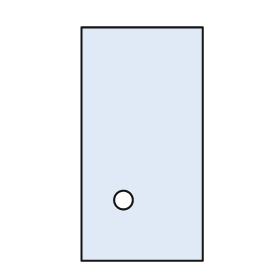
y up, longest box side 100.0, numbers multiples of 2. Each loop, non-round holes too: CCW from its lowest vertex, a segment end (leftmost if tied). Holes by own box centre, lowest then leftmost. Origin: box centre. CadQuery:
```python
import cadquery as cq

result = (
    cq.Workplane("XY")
    .moveTo(-26.0, -50.0)
    .lineTo(26.0, -50.0)
    .lineTo(26.0, 50.0)
    .lineTo(-26.0, 50.0)
    .close()
    .moveTo(-8.0, -24.0)
    .circle(4.0)
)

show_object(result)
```